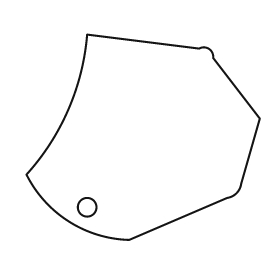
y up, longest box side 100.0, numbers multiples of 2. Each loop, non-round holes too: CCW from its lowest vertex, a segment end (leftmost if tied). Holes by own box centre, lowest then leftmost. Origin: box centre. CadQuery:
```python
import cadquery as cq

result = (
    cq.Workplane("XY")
    .moveTo(-6.0, -44.0)
    .lineTo(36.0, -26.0)
    .threePointArc((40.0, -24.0), (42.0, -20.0))
    .lineTo(50.0, 8.0)
    .lineTo(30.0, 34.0)
    .threePointArc((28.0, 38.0), (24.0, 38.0))
    .lineTo(-24.0, 44.0)
    .threePointArc((-32.0, 12.0), (-50.0, -16.0))
    .threePointArc((-32.0, -36.0), (-6.0, -44.0))
    .close()
    .moveTo(-24.0, -30.0)
    .circle(4.0)
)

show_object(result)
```